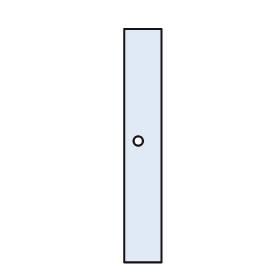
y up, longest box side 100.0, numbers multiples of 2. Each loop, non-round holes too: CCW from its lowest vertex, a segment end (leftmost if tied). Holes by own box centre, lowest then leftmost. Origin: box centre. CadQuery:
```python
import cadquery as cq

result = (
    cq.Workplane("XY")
    .moveTo(-8.0, -50.0)
    .lineTo(8.0, -50.0)
    .lineTo(8.0, 50.0)
    .lineTo(-8.0, 50.0)
    .close()
    .moveTo(-2.0, 2.0)
    .circle(2.0)
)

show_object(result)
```